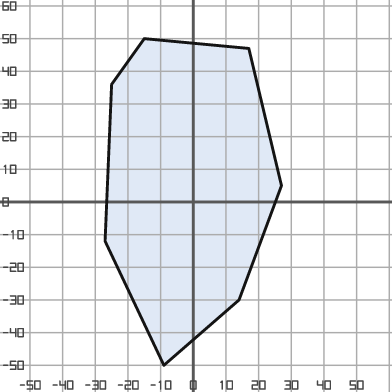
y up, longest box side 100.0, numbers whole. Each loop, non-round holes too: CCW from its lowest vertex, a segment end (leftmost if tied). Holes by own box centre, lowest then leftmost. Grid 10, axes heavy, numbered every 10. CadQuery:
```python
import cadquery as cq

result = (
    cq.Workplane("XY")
    .moveTo(-9.0, -50.0)
    .lineTo(14.0, -30.0)
    .lineTo(27.0, 5.0)
    .lineTo(17.0, 47.0)
    .lineTo(-15.0, 50.0)
    .lineTo(-25.0, 36.0)
    .lineTo(-27.0, -12.0)
    .close()
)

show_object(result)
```